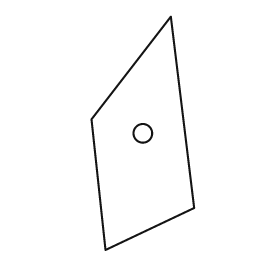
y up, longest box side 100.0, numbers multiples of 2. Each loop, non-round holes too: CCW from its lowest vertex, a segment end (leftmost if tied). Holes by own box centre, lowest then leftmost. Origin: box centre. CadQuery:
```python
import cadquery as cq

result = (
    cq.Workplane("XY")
    .moveTo(-16.0, -50.0)
    .lineTo(22.0, -32.0)
    .lineTo(12.0, 50.0)
    .lineTo(-22.0, 6.0)
    .close()
    .moveTo(0.0, 0.0)
    .circle(4.0)
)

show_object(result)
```